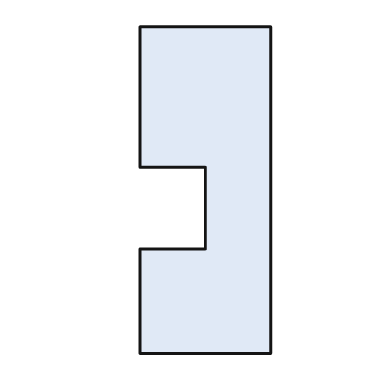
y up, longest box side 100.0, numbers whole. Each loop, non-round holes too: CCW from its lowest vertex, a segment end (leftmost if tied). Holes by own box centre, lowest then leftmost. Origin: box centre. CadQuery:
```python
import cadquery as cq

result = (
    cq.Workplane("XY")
    .moveTo(-20.0, -50.0)
    .lineTo(20.0, -50.0)
    .lineTo(20.0, 50.0)
    .lineTo(-20.0, 50.0)
    .lineTo(-20.0, 7.0)
    .lineTo(0.0, 7.0)
    .lineTo(0.0, -18.0)
    .lineTo(-20.0, -18.0)
    .close()
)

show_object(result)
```